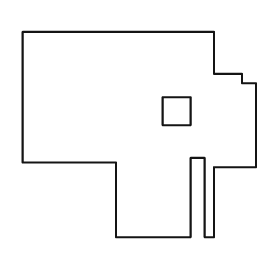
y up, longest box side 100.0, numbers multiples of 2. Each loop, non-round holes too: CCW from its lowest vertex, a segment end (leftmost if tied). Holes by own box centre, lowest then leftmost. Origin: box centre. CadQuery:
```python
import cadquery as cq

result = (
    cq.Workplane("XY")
    .moveTo(-10.0, -44.0)
    .lineTo(22.0, -44.0)
    .lineTo(22.0, -10.0)
    .lineTo(28.0, -10.0)
    .lineTo(28.0, -44.0)
    .lineTo(32.0, -44.0)
    .lineTo(32.0, -14.0)
    .lineTo(50.0, -14.0)
    .lineTo(50.0, 22.0)
    .lineTo(44.0, 22.0)
    .lineTo(44.0, 26.0)
    .lineTo(32.0, 26.0)
    .lineTo(32.0, 44.0)
    .lineTo(-50.0, 44.0)
    .lineTo(-50.0, -12.0)
    .lineTo(-10.0, -12.0)
    .close()
    .moveTo(10.0, 4.0)
    .lineTo(22.0, 4.0)
    .lineTo(22.0, 16.0)
    .lineTo(10.0, 16.0)
    .close()
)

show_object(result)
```